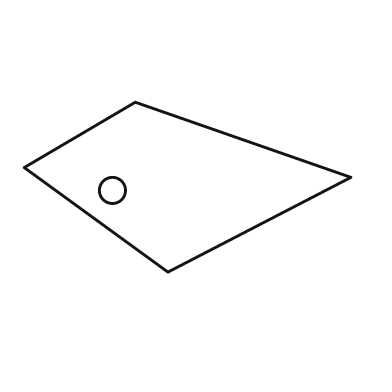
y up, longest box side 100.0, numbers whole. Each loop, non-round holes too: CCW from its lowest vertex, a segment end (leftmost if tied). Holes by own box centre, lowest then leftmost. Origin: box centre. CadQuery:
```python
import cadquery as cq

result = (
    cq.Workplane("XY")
    .moveTo(-6.0, -26.0)
    .lineTo(50.0, 3.0)
    .lineTo(-16.0, 26.0)
    .lineTo(-50.0, 6.0)
    .close()
    .moveTo(-23.0, -1.0)
    .circle(4.0)
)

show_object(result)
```